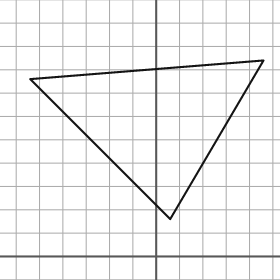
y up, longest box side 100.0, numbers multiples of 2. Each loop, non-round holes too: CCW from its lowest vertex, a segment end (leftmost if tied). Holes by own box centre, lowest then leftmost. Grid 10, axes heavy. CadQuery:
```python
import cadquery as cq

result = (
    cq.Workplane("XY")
    .moveTo(6.0, 16.0)
    .lineTo(46.0, 84.0)
    .lineTo(-54.0, 76.0)
    .close()
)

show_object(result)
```